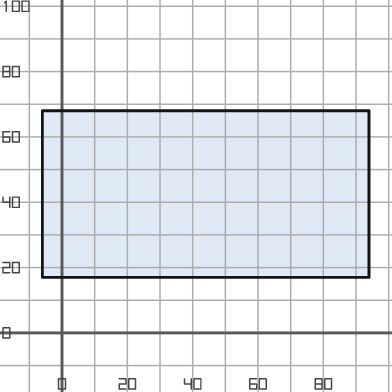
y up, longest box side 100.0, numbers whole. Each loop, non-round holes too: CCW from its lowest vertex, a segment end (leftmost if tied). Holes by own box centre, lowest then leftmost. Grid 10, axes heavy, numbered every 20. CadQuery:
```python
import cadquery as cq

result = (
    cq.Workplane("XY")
    .moveTo(-6.0, 17.0)
    .lineTo(94.0, 17.0)
    .lineTo(94.0, 68.0)
    .lineTo(-6.0, 68.0)
    .close()
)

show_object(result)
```